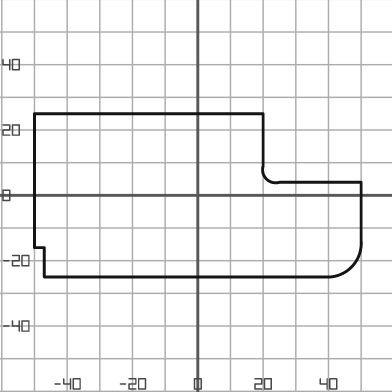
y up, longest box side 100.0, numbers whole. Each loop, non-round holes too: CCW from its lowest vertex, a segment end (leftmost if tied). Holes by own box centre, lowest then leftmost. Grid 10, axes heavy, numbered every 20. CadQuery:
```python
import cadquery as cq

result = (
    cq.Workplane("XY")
    .moveTo(-47.0, -25.0)
    .lineTo(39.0, -25.0)
    .threePointArc((47.0, -22.0), (50.0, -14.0))
    .lineTo(50.0, 4.0)
    .lineTo(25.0, 4.0)
    .threePointArc((21.0, 5.0), (20.0, 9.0))
    .lineTo(20.0, 25.0)
    .lineTo(-50.0, 25.0)
    .lineTo(-50.0, -16.0)
    .lineTo(-47.0, -16.0)
    .close()
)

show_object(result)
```